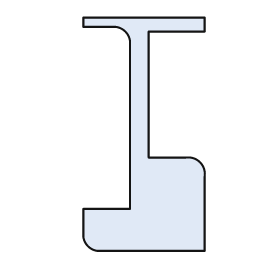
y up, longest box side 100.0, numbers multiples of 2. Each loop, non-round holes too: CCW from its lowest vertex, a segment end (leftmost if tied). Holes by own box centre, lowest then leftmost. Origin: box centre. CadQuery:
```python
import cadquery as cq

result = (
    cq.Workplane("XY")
    .moveTo(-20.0, -50.0)
    .lineTo(26.0, -50.0)
    .lineTo(26.0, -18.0)
    .threePointArc((24.0, -12.0), (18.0, -10.0))
    .lineTo(2.0, -10.0)
    .lineTo(2.0, 44.0)
    .lineTo(26.0, 44.0)
    .lineTo(26.0, 50.0)
    .lineTo(-26.0, 50.0)
    .lineTo(-26.0, 46.0)
    .lineTo(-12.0, 46.0)
    .threePointArc((-8.0, 44.0), (-6.0, 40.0))
    .lineTo(-6.0, -32.0)
    .lineTo(-26.0, -32.0)
    .lineTo(-26.0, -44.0)
    .threePointArc((-24.0, -48.0), (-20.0, -50.0))
    .close()
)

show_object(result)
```